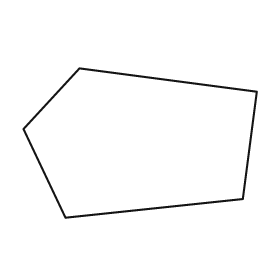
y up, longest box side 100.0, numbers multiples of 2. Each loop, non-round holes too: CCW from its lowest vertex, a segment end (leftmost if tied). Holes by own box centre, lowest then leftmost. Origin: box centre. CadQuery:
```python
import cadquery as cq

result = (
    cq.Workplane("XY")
    .moveTo(-32.0, -32.0)
    .lineTo(44.0, -24.0)
    .lineTo(50.0, 22.0)
    .lineTo(-26.0, 32.0)
    .lineTo(-50.0, 6.0)
    .close()
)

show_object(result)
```